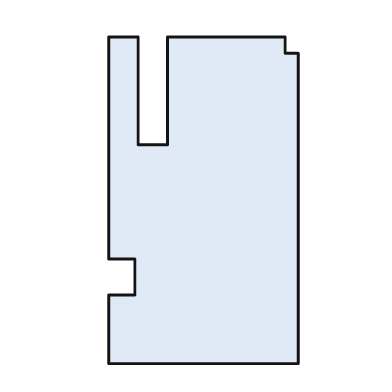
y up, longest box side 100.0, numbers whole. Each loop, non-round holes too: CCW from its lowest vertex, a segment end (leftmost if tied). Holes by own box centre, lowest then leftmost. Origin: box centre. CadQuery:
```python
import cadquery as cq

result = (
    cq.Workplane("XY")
    .moveTo(-29.0, -50.0)
    .lineTo(29.0, -50.0)
    .lineTo(29.0, 45.0)
    .lineTo(25.0, 45.0)
    .lineTo(25.0, 50.0)
    .lineTo(-11.0, 50.0)
    .lineTo(-11.0, 17.0)
    .lineTo(-20.0, 17.0)
    .lineTo(-20.0, 50.0)
    .lineTo(-29.0, 50.0)
    .lineTo(-29.0, -18.0)
    .lineTo(-21.0, -18.0)
    .lineTo(-21.0, -29.0)
    .lineTo(-29.0, -29.0)
    .close()
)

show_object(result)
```